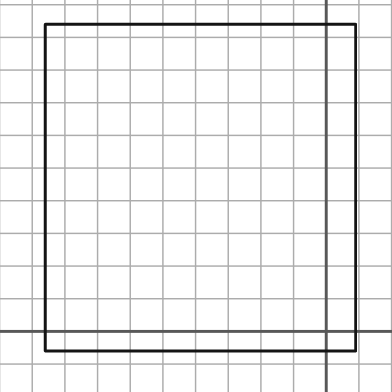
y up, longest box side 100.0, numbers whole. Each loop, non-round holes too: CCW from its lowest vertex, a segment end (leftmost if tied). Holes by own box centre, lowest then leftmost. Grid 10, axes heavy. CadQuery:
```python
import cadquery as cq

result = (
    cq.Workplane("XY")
    .moveTo(-86.0, -6.0)
    .lineTo(9.0, -6.0)
    .lineTo(9.0, 94.0)
    .lineTo(-86.0, 94.0)
    .close()
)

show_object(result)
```